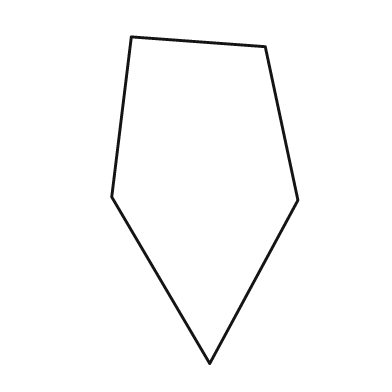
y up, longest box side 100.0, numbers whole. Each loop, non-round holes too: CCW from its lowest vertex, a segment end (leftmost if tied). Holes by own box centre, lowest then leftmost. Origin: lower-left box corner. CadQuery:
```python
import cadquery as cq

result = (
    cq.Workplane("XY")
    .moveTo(30.0, 0.0)
    .lineTo(57.0, 50.0)
    .lineTo(47.0, 97.0)
    .lineTo(6.0, 100.0)
    .lineTo(0.0, 51.0)
    .close()
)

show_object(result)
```